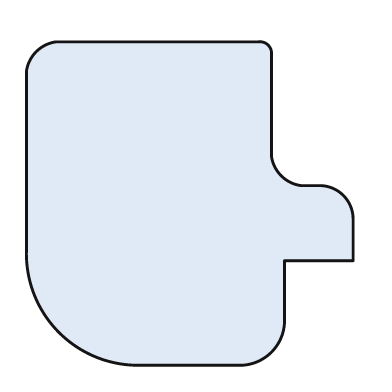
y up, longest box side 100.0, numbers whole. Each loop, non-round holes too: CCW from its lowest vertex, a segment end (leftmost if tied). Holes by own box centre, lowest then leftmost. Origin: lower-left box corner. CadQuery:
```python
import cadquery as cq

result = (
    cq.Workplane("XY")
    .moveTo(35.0, 0.0)
    .lineTo(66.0, 0.0)
    .threePointArc((75.0, 4.0), (79.0, 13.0))
    .lineTo(79.0, 32.0)
    .lineTo(100.0, 32.0)
    .lineTo(100.0, 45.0)
    .threePointArc((97.0, 52.0), (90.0, 55.0))
    .lineTo(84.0, 55.0)
    .threePointArc((78.0, 58.0), (75.0, 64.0))
    .lineTo(75.0, 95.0)
    .threePointArc((74.0, 98.0), (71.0, 99.0))
    .lineTo(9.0, 99.0)
    .threePointArc((3.0, 96.0), (0.0, 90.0))
    .lineTo(0.0, 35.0)
    .threePointArc((10.0, 10.0), (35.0, 0.0))
    .close()
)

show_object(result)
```